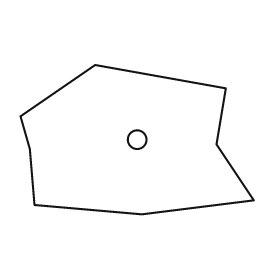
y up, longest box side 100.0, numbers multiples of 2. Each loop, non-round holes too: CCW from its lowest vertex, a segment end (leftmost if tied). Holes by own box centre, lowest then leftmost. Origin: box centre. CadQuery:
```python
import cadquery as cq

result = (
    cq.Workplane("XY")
    .moveTo(2.0, -32.0)
    .lineTo(50.0, -26.0)
    .lineTo(34.0, -2.0)
    .lineTo(38.0, 22.0)
    .lineTo(-18.0, 32.0)
    .lineTo(-50.0, 10.0)
    .lineTo(-46.0, -4.0)
    .lineTo(-44.0, -28.0)
    .close()
    .moveTo(0.0, 0.0)
    .circle(4.0)
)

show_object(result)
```